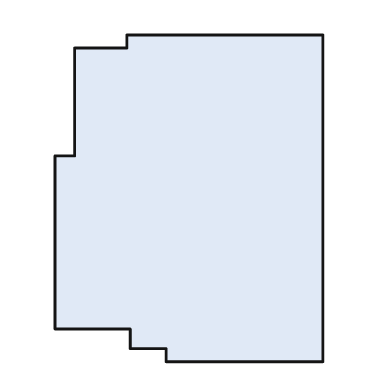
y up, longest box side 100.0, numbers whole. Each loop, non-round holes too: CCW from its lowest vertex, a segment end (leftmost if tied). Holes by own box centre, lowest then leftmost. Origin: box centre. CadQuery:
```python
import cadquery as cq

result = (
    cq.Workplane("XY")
    .moveTo(-7.0, -50.0)
    .lineTo(41.0, -50.0)
    .lineTo(41.0, 50.0)
    .lineTo(-19.0, 50.0)
    .lineTo(-19.0, 46.0)
    .lineTo(-35.0, 46.0)
    .lineTo(-35.0, 13.0)
    .lineTo(-41.0, 13.0)
    .lineTo(-41.0, -40.0)
    .lineTo(-18.0, -40.0)
    .lineTo(-18.0, -46.0)
    .lineTo(-7.0, -46.0)
    .close()
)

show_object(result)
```